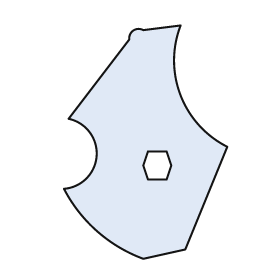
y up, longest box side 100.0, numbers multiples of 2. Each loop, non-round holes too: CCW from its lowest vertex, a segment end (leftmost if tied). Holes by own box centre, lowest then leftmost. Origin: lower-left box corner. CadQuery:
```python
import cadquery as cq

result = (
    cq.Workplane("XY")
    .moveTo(34.0, 0.0)
    .lineTo(52.0, 4.0)
    .lineTo(70.0, 48.0)
    .threePointArc((50.0, 70.0), (50.0, 100.0))
    .lineTo(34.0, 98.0)
    .threePointArc((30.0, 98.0), (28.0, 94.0))
    .lineTo(2.0, 60.0)
    .threePointArc((14.0, 44.0), (0.0, 30.0))
    .threePointArc((14.0, 12.0), (34.0, 0.0))
    .close()
    .moveTo(36.0, 34.0)
    .lineTo(44.0, 34.0)
    .lineTo(46.0, 40.0)
    .lineTo(44.0, 46.0)
    .lineTo(36.0, 46.0)
    .lineTo(34.0, 40.0)
    .close()
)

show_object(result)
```